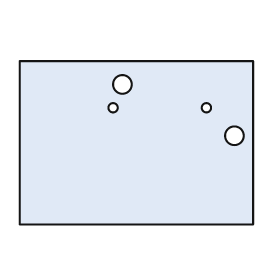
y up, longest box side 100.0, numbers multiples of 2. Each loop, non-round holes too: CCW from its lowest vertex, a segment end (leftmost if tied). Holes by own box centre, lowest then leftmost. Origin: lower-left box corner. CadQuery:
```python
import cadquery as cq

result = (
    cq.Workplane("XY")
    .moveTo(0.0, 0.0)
    .lineTo(100.0, 0.0)
    .lineTo(100.0, 70.0)
    .lineTo(0.0, 70.0)
    .close()
    .moveTo(92.0, 38.0)
    .circle(4.0)
    .moveTo(40.0, 50.0)
    .circle(2.0)
    .moveTo(80.0, 50.0)
    .circle(2.0)
    .moveTo(44.0, 60.0)
    .circle(4.0)
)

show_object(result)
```